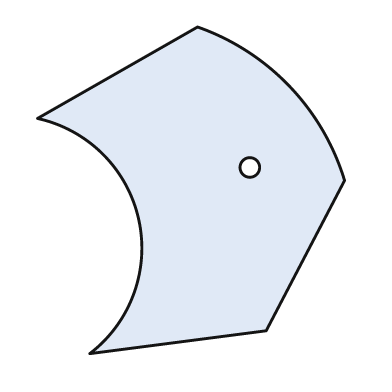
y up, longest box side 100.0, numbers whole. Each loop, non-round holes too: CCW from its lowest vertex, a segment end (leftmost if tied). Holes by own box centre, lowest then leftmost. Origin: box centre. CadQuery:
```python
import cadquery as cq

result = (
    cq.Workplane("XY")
    .moveTo(-31.0, -50.0)
    .lineTo(23.0, -43.0)
    .lineTo(47.0, 3.0)
    .threePointArc((30.0, 32.0), (2.0, 50.0))
    .lineTo(-47.0, 22.0)
    .threePointArc((-16.0, -9.0), (-31.0, -50.0))
    .close()
    .moveTo(18.0, 7.0)
    .circle(3.0)
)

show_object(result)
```